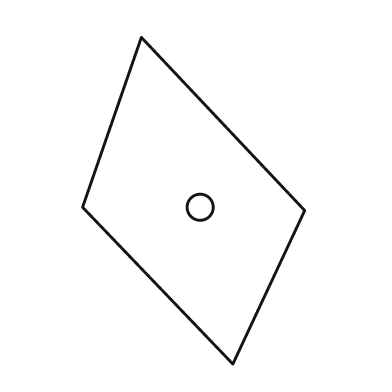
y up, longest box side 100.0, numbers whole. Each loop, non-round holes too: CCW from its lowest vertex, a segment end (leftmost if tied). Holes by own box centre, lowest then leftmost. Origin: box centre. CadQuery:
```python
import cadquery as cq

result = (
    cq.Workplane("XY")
    .moveTo(12.0, -50.0)
    .lineTo(34.0, -3.0)
    .lineTo(-16.0, 50.0)
    .lineTo(-34.0, -2.0)
    .close()
    .moveTo(2.0, -2.0)
    .circle(4.0)
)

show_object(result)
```